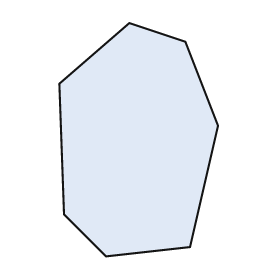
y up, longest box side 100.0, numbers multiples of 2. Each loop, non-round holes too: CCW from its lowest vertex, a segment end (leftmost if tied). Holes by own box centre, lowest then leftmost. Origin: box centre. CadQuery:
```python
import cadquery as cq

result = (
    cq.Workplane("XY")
    .moveTo(-14.0, -50.0)
    .lineTo(22.0, -46.0)
    .lineTo(34.0, 6.0)
    .lineTo(20.0, 42.0)
    .lineTo(-4.0, 50.0)
    .lineTo(-34.0, 24.0)
    .lineTo(-32.0, -32.0)
    .close()
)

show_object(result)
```